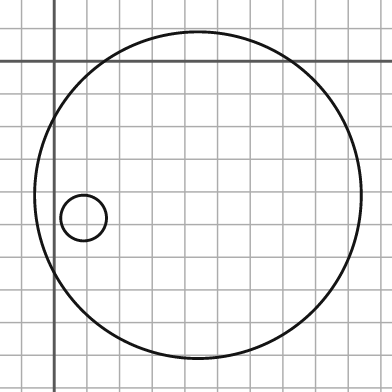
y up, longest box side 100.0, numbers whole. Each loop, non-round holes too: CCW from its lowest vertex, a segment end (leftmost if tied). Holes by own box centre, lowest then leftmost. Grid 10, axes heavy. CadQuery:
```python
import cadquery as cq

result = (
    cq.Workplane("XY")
    .moveTo(44.0, -41.0)
    .circle(50.0)
    .moveTo(9.0, -48.0)
    .circle(7.0)
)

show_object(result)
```